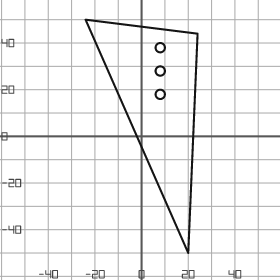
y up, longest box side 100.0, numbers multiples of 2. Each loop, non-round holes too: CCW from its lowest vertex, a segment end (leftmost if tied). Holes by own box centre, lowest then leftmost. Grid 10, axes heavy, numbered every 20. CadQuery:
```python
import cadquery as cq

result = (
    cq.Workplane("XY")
    .moveTo(20.0, -50.0)
    .lineTo(24.0, 44.0)
    .lineTo(-24.0, 50.0)
    .close()
    .moveTo(8.0, 18.0)
    .circle(2.0)
    .moveTo(8.0, 28.0)
    .circle(2.0)
    .moveTo(8.0, 38.0)
    .circle(2.0)
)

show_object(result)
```